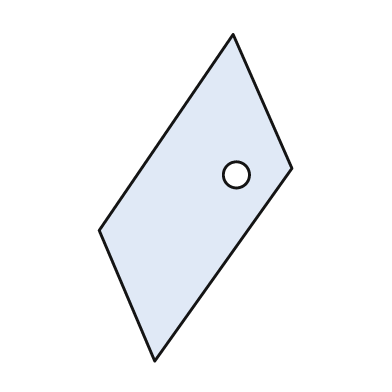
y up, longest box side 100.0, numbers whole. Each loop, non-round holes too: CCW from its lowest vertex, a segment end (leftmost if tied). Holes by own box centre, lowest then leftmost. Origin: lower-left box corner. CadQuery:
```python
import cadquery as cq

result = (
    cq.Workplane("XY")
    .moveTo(17.0, 0.0)
    .lineTo(59.0, 59.0)
    .lineTo(41.0, 100.0)
    .lineTo(0.0, 40.0)
    .close()
    .moveTo(42.0, 57.0)
    .circle(4.0)
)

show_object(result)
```